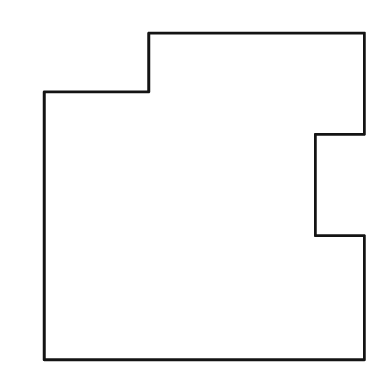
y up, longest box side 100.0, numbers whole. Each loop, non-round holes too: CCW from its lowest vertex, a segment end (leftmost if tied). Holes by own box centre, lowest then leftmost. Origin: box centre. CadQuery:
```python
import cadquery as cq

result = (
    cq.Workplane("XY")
    .moveTo(-49.0, -50.0)
    .lineTo(49.0, -50.0)
    .lineTo(49.0, -12.0)
    .lineTo(34.0, -12.0)
    .lineTo(34.0, 19.0)
    .lineTo(49.0, 19.0)
    .lineTo(49.0, 50.0)
    .lineTo(-17.0, 50.0)
    .lineTo(-17.0, 32.0)
    .lineTo(-49.0, 32.0)
    .close()
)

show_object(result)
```